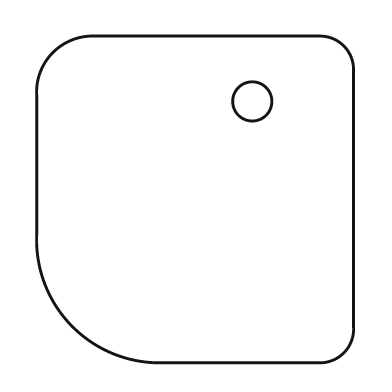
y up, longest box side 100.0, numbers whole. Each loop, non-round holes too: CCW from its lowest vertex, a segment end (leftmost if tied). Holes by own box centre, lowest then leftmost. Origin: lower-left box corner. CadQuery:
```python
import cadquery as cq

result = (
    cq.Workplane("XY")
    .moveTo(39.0, 0.0)
    .lineTo(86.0, 0.0)
    .threePointArc((94.0, 3.0), (97.0, 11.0))
    .lineTo(97.0, 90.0)
    .threePointArc((94.0, 97.0), (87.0, 100.0))
    .lineTo(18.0, 100.0)
    .threePointArc((5.0, 95.0), (0.0, 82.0))
    .lineTo(0.0, 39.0)
    .threePointArc((11.0, 11.0), (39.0, 0.0))
    .close()
    .moveTo(66.0, 80.0)
    .circle(6.0)
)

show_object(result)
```